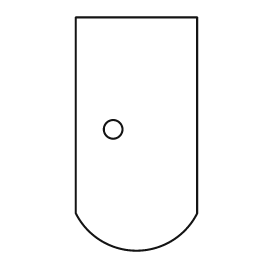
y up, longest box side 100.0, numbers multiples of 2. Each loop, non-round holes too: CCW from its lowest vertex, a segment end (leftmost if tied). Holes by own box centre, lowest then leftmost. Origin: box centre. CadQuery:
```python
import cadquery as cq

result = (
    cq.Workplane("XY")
    .moveTo(-26.0, -34.0)
    .threePointArc((0.0, -50.0), (26.0, -34.0))
    .lineTo(26.0, 50.0)
    .lineTo(-26.0, 50.0)
    .close()
    .moveTo(-10.0, 2.0)
    .circle(4.0)
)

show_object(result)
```